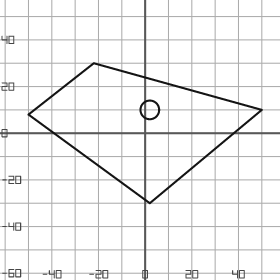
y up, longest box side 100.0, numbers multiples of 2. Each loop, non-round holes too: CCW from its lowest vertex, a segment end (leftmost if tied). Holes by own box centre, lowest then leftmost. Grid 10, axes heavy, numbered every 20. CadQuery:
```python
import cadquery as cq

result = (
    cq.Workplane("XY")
    .moveTo(2.0, -30.0)
    .lineTo(50.0, 10.0)
    .lineTo(-22.0, 30.0)
    .lineTo(-50.0, 8.0)
    .close()
    .moveTo(2.0, 10.0)
    .circle(4.0)
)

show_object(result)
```